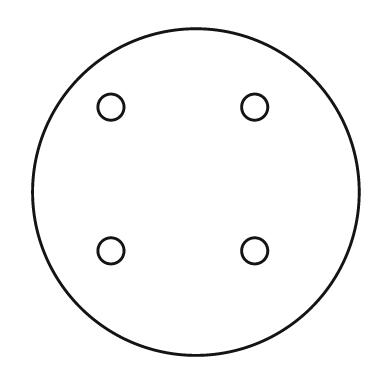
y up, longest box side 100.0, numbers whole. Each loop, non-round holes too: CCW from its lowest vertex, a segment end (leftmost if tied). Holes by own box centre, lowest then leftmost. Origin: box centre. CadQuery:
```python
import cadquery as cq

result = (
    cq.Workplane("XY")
    .moveTo(0.0, 0.0)
    .circle(50.0)
    .moveTo(-26.0, -18.0)
    .circle(4.0)
    .moveTo(18.0, -18.0)
    .circle(4.0)
    .moveTo(-26.0, 26.0)
    .circle(4.0)
    .moveTo(18.0, 26.0)
    .circle(4.0)
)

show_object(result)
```